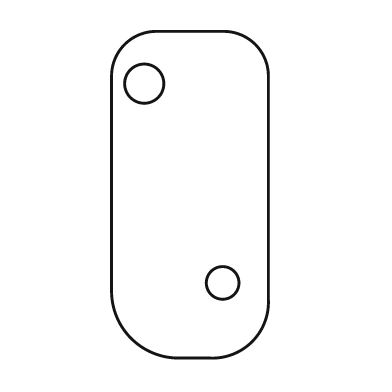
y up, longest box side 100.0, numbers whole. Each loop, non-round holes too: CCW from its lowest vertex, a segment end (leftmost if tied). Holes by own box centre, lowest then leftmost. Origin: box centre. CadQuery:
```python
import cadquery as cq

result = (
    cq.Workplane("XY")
    .moveTo(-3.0, -50.0)
    .lineTo(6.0, -50.0)
    .threePointArc((19.0, -45.0), (24.0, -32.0))
    .lineTo(24.0, 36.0)
    .threePointArc((20.0, 46.0), (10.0, 50.0))
    .lineTo(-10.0, 50.0)
    .threePointArc((-20.0, 46.0), (-24.0, 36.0))
    .lineTo(-24.0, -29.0)
    .threePointArc((-18.0, -44.0), (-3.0, -50.0))
    .close()
    .moveTo(10.0, -27.0)
    .circle(5.0)
    .moveTo(-14.0, 34.0)
    .circle(6.0)
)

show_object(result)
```